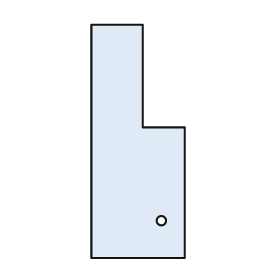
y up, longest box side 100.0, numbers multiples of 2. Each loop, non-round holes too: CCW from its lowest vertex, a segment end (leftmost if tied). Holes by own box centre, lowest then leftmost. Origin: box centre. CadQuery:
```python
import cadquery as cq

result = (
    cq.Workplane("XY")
    .moveTo(-20.0, -50.0)
    .lineTo(20.0, -50.0)
    .lineTo(20.0, 6.0)
    .lineTo(2.0, 6.0)
    .lineTo(2.0, 50.0)
    .lineTo(-20.0, 50.0)
    .close()
    .moveTo(10.0, -34.0)
    .circle(2.0)
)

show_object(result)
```